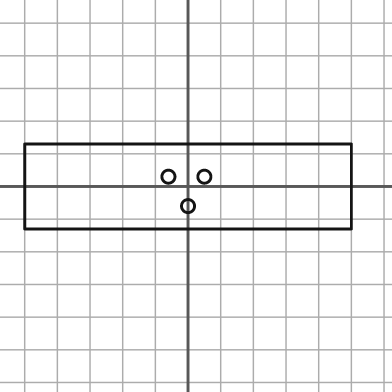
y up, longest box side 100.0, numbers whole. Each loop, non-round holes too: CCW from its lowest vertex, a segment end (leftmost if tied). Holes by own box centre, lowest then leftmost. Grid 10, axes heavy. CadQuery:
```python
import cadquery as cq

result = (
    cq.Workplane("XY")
    .moveTo(-50.0, -13.0)
    .lineTo(50.0, -13.0)
    .lineTo(50.0, 13.0)
    .lineTo(-50.0, 13.0)
    .close()
    .moveTo(0.0, -6.0)
    .circle(2.0)
    .moveTo(-6.0, 3.0)
    .circle(2.0)
    .moveTo(5.0, 3.0)
    .circle(2.0)
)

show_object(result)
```